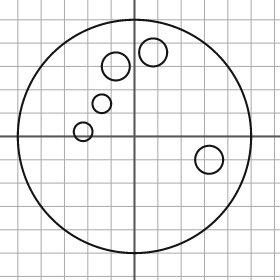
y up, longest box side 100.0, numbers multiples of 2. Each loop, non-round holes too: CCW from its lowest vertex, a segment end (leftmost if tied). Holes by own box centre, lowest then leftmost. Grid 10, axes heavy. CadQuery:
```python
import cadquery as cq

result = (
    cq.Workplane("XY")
    .moveTo(0.0, 0.0)
    .circle(50.0)
    .moveTo(32.0, -10.0)
    .circle(6.0)
    .moveTo(-22.0, 2.0)
    .circle(4.0)
    .moveTo(-14.0, 14.0)
    .circle(4.0)
    .moveTo(-8.0, 30.0)
    .circle(6.0)
    .moveTo(8.0, 36.0)
    .circle(6.0)
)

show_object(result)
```